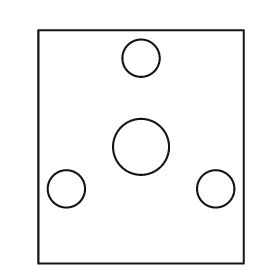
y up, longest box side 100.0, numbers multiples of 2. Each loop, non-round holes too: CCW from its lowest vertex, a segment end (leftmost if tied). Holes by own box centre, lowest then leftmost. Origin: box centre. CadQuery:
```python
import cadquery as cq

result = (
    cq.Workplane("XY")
    .moveTo(-44.0, -50.0)
    .lineTo(44.0, -50.0)
    .lineTo(44.0, 50.0)
    .lineTo(-44.0, 50.0)
    .close()
    .moveTo(-32.0, -18.0)
    .circle(8.0)
    .moveTo(32.0, -18.0)
    .circle(8.0)
    .moveTo(0.0, 0.0)
    .circle(12.0)
    .moveTo(0.0, 38.0)
    .circle(8.0)
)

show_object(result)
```